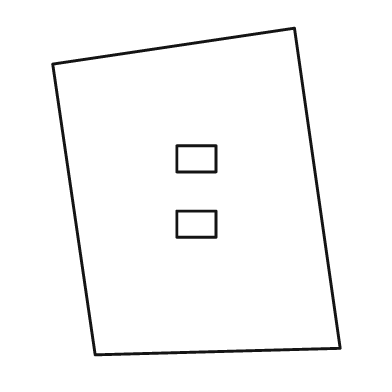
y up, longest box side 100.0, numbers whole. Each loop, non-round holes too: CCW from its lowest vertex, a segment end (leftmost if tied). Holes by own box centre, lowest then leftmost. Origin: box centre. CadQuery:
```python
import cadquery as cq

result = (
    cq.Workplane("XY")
    .moveTo(-31.0, -50.0)
    .lineTo(44.0, -48.0)
    .lineTo(30.0, 50.0)
    .lineTo(-44.0, 39.0)
    .close()
    .moveTo(-6.0, -14.0)
    .lineTo(6.0, -14.0)
    .lineTo(6.0, -6.0)
    .lineTo(-6.0, -6.0)
    .close()
    .moveTo(-6.0, 6.0)
    .lineTo(6.0, 6.0)
    .lineTo(6.0, 14.0)
    .lineTo(-6.0, 14.0)
    .close()
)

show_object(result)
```